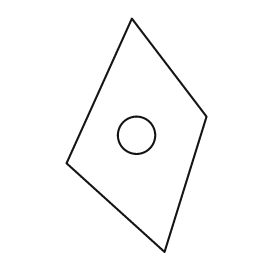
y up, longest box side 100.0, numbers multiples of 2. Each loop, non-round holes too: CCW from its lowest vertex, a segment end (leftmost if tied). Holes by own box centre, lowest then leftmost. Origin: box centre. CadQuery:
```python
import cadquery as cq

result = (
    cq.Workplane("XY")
    .moveTo(12.0, -50.0)
    .lineTo(30.0, 8.0)
    .lineTo(-2.0, 50.0)
    .lineTo(-30.0, -12.0)
    .close()
    .moveTo(0.0, 0.0)
    .circle(8.0)
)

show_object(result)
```